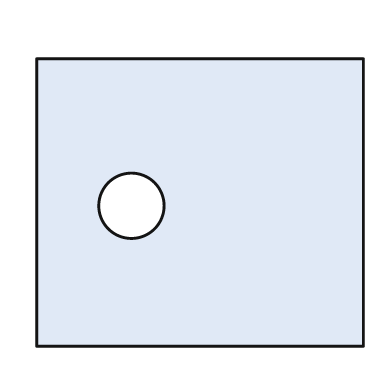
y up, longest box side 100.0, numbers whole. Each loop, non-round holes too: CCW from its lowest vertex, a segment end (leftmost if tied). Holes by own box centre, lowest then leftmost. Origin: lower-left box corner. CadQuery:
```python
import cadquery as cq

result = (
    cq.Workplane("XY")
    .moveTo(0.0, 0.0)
    .lineTo(100.0, 0.0)
    .lineTo(100.0, 88.0)
    .lineTo(0.0, 88.0)
    .close()
    .moveTo(29.0, 43.0)
    .circle(10.0)
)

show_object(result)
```